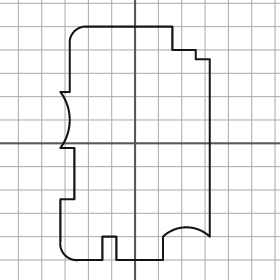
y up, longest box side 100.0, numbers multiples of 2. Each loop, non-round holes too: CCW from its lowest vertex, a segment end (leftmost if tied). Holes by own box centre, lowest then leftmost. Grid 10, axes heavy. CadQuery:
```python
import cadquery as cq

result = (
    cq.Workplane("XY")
    .moveTo(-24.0, -50.0)
    .lineTo(-14.0, -50.0)
    .lineTo(-14.0, -40.0)
    .lineTo(-8.0, -40.0)
    .lineTo(-8.0, -50.0)
    .lineTo(12.0, -50.0)
    .lineTo(12.0, -40.0)
    .threePointArc((22.0, -36.0), (32.0, -40.0))
    .lineTo(32.0, 36.0)
    .lineTo(26.0, 36.0)
    .lineTo(26.0, 40.0)
    .lineTo(16.0, 40.0)
    .lineTo(16.0, 50.0)
    .lineTo(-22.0, 50.0)
    .threePointArc((-26.0, 48.0), (-28.0, 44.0))
    .lineTo(-28.0, 22.0)
    .lineTo(-32.0, 22.0)
    .threePointArc((-28.0, 10.0), (-32.0, -2.0))
    .lineTo(-26.0, -2.0)
    .lineTo(-26.0, -24.0)
    .lineTo(-32.0, -24.0)
    .lineTo(-32.0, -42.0)
    .threePointArc((-30.0, -48.0), (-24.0, -50.0))
    .close()
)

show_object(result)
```